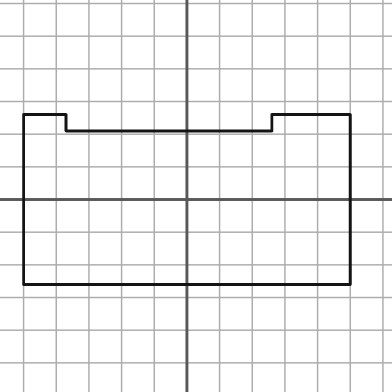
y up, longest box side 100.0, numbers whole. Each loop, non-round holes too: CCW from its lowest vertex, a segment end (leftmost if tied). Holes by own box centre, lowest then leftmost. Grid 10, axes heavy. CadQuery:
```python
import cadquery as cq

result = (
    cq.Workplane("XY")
    .moveTo(-50.0, -26.0)
    .lineTo(50.0, -26.0)
    .lineTo(50.0, 26.0)
    .lineTo(26.0, 26.0)
    .lineTo(26.0, 21.0)
    .lineTo(-37.0, 21.0)
    .lineTo(-37.0, 26.0)
    .lineTo(-50.0, 26.0)
    .close()
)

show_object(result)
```